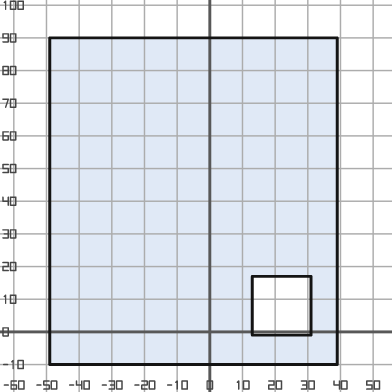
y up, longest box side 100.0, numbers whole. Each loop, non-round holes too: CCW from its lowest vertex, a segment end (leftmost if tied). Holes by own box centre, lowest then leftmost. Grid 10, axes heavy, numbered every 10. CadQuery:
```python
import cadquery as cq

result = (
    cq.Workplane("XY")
    .moveTo(-49.0, -10.0)
    .lineTo(39.0, -10.0)
    .lineTo(39.0, 90.0)
    .lineTo(-49.0, 90.0)
    .close()
    .moveTo(13.0, -1.0)
    .lineTo(31.0, -1.0)
    .lineTo(31.0, 17.0)
    .lineTo(13.0, 17.0)
    .close()
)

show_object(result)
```